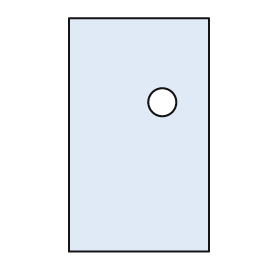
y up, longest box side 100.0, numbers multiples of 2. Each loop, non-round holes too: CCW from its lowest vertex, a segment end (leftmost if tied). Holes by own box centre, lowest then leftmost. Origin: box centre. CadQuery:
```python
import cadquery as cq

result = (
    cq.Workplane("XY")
    .moveTo(-30.0, -50.0)
    .lineTo(30.0, -50.0)
    .lineTo(30.0, 50.0)
    .lineTo(-30.0, 50.0)
    .close()
    .moveTo(10.0, 14.0)
    .circle(6.0)
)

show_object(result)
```